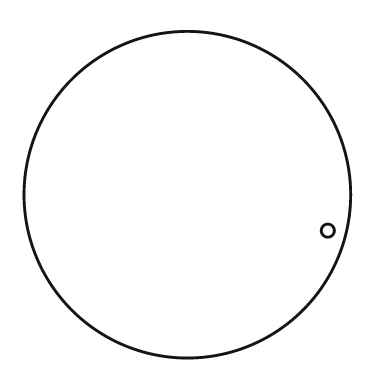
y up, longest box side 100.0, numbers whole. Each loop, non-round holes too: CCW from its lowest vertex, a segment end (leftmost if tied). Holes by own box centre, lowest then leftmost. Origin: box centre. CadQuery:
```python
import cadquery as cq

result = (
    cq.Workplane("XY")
    .moveTo(0.0, 0.0)
    .circle(50.0)
    .moveTo(43.0, -11.0)
    .circle(2.0)
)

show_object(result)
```